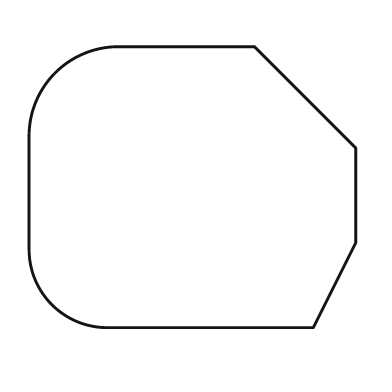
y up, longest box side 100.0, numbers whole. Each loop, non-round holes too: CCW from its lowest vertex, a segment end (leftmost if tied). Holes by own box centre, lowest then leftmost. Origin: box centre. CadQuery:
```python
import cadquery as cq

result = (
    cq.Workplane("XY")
    .moveTo(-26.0, -43.0)
    .lineTo(37.0, -43.0)
    .lineTo(50.0, -17.0)
    .lineTo(50.0, 12.0)
    .lineTo(19.0, 43.0)
    .lineTo(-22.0, 43.0)
    .threePointArc((-42.0, 35.0), (-50.0, 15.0))
    .lineTo(-50.0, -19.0)
    .threePointArc((-43.0, -36.0), (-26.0, -43.0))
    .close()
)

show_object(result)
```